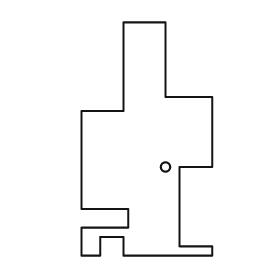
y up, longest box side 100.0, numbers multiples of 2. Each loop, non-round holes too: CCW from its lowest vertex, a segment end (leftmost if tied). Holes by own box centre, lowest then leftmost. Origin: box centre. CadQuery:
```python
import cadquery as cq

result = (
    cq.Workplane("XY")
    .moveTo(-28.0, -50.0)
    .lineTo(-20.0, -50.0)
    .lineTo(-20.0, -42.0)
    .lineTo(-10.0, -42.0)
    .lineTo(-10.0, -50.0)
    .lineTo(28.0, -50.0)
    .lineTo(28.0, -46.0)
    .lineTo(14.0, -46.0)
    .lineTo(14.0, -12.0)
    .lineTo(28.0, -12.0)
    .lineTo(28.0, 18.0)
    .lineTo(8.0, 18.0)
    .lineTo(8.0, 50.0)
    .lineTo(-10.0, 50.0)
    .lineTo(-10.0, 12.0)
    .lineTo(-28.0, 12.0)
    .lineTo(-28.0, -30.0)
    .lineTo(-8.0, -30.0)
    .lineTo(-8.0, -38.0)
    .lineTo(-28.0, -38.0)
    .close()
    .moveTo(8.0, -12.0)
    .circle(2.0)
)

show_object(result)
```